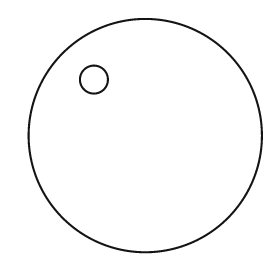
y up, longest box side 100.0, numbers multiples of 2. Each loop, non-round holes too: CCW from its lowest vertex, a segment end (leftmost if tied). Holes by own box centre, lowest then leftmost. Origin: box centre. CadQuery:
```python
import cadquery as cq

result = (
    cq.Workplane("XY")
    .moveTo(0.0, 0.0)
    .circle(50.0)
    .moveTo(-22.0, 24.0)
    .circle(6.0)
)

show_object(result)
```